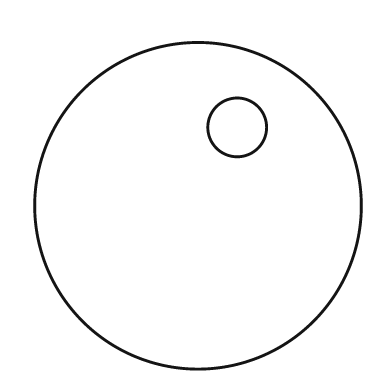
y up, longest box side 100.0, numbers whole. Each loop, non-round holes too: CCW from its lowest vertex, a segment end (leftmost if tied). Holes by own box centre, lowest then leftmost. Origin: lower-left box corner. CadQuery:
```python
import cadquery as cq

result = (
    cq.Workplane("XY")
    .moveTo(50.0, 50.0)
    .circle(50.0)
    .moveTo(62.0, 74.0)
    .circle(9.0)
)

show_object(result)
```